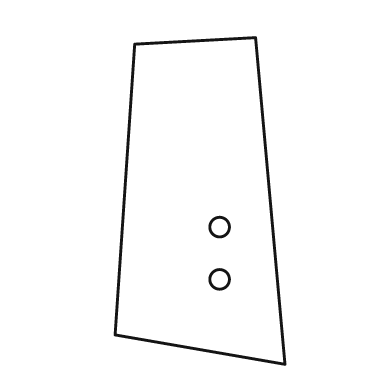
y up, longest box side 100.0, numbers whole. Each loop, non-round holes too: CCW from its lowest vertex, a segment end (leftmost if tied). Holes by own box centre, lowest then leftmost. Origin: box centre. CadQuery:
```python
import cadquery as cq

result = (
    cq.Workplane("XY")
    .moveTo(26.0, -50.0)
    .lineTo(17.0, 50.0)
    .lineTo(-20.0, 48.0)
    .lineTo(-26.0, -41.0)
    .close()
    .moveTo(6.0, -24.0)
    .circle(3.0)
    .moveTo(6.0, -8.0)
    .circle(3.0)
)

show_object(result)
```